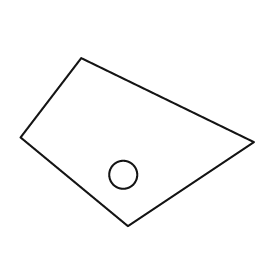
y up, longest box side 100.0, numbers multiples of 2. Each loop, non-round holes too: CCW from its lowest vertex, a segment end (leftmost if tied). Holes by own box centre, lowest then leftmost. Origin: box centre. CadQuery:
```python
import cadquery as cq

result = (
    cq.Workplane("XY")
    .moveTo(-4.0, -36.0)
    .lineTo(50.0, 0.0)
    .lineTo(-24.0, 36.0)
    .lineTo(-50.0, 2.0)
    .close()
    .moveTo(-6.0, -14.0)
    .circle(6.0)
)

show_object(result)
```